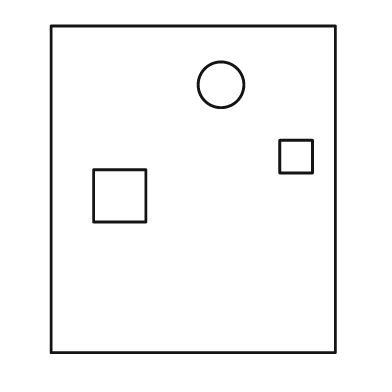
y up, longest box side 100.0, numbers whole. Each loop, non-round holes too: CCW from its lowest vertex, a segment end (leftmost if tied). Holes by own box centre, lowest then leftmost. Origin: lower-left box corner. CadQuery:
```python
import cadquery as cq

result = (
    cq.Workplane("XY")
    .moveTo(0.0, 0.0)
    .lineTo(87.0, 0.0)
    .lineTo(87.0, 100.0)
    .lineTo(0.0, 100.0)
    .close()
    .moveTo(13.0, 40.0)
    .lineTo(29.0, 40.0)
    .lineTo(29.0, 56.0)
    .lineTo(13.0, 56.0)
    .close()
    .moveTo(70.0, 55.0)
    .lineTo(80.0, 55.0)
    .lineTo(80.0, 65.0)
    .lineTo(70.0, 65.0)
    .close()
    .moveTo(52.0, 82.0)
    .circle(7.0)
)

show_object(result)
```